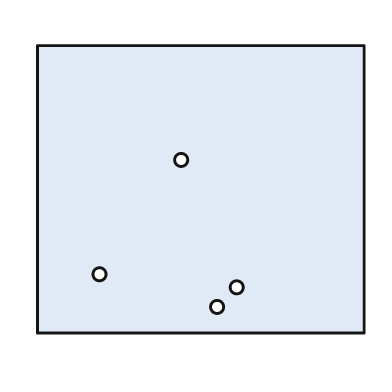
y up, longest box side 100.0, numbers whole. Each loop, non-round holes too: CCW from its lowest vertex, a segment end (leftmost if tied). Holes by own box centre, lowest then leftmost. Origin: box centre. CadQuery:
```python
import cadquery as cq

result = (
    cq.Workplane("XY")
    .moveTo(-50.0, -44.0)
    .lineTo(50.0, -44.0)
    .lineTo(50.0, 44.0)
    .lineTo(-50.0, 44.0)
    .close()
    .moveTo(5.0, -36.0)
    .circle(2.0)
    .moveTo(11.0, -30.0)
    .circle(2.0)
    .moveTo(-31.0, -26.0)
    .circle(2.0)
    .moveTo(-6.0, 9.0)
    .circle(2.0)
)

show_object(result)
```